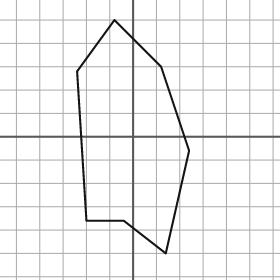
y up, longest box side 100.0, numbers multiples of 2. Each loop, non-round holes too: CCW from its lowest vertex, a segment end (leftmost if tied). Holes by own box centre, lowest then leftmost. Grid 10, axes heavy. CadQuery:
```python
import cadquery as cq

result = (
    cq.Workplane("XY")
    .moveTo(14.0, -50.0)
    .lineTo(24.0, -6.0)
    .lineTo(12.0, 30.0)
    .lineTo(-8.0, 50.0)
    .lineTo(-24.0, 28.0)
    .lineTo(-20.0, -36.0)
    .lineTo(-4.0, -36.0)
    .close()
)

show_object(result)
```